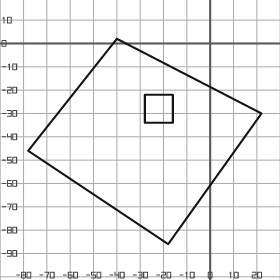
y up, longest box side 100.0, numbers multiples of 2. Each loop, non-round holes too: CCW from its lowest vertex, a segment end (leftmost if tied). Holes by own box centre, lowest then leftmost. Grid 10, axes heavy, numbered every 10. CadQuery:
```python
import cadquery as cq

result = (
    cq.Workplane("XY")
    .moveTo(-18.0, -86.0)
    .lineTo(22.0, -30.0)
    .lineTo(-40.0, 2.0)
    .lineTo(-78.0, -46.0)
    .close()
    .moveTo(-28.0, -34.0)
    .lineTo(-16.0, -34.0)
    .lineTo(-16.0, -22.0)
    .lineTo(-28.0, -22.0)
    .close()
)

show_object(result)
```